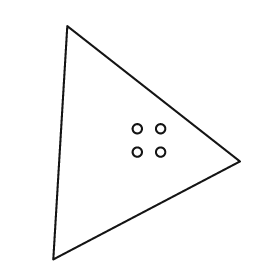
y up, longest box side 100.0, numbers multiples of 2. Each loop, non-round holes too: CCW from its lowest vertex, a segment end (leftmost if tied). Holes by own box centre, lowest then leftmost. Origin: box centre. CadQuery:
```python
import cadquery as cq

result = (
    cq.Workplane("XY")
    .moveTo(-40.0, -50.0)
    .lineTo(40.0, -8.0)
    .lineTo(-34.0, 50.0)
    .close()
    .moveTo(-4.0, -4.0)
    .circle(2.0)
    .moveTo(6.0, -4.0)
    .circle(2.0)
    .moveTo(-4.0, 6.0)
    .circle(2.0)
    .moveTo(6.0, 6.0)
    .circle(2.0)
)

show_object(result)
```